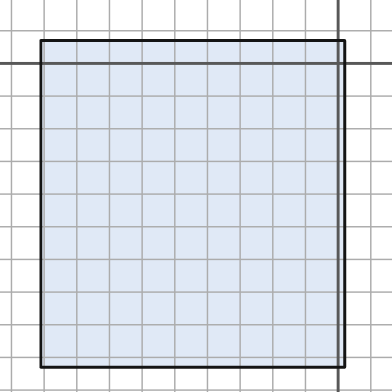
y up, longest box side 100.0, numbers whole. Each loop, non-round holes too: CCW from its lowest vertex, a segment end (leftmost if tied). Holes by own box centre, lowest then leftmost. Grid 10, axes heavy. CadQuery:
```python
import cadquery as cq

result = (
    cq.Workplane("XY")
    .moveTo(-91.0, -93.0)
    .lineTo(2.0, -93.0)
    .lineTo(2.0, 7.0)
    .lineTo(-91.0, 7.0)
    .close()
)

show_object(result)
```